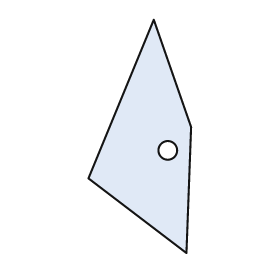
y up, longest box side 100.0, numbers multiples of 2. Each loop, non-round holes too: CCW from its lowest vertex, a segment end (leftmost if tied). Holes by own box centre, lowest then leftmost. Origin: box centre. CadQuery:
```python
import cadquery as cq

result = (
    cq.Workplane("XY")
    .moveTo(20.0, -50.0)
    .lineTo(22.0, 4.0)
    .lineTo(6.0, 50.0)
    .lineTo(-22.0, -18.0)
    .close()
    .moveTo(12.0, -6.0)
    .circle(4.0)
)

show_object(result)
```